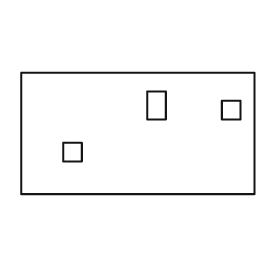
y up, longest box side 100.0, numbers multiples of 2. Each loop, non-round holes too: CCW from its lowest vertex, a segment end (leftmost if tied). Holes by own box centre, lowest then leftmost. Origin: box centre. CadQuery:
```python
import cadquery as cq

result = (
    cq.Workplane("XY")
    .moveTo(-50.0, -26.0)
    .lineTo(50.0, -26.0)
    .lineTo(50.0, 26.0)
    .lineTo(-50.0, 26.0)
    .close()
    .moveTo(-32.0, -12.0)
    .lineTo(-24.0, -12.0)
    .lineTo(-24.0, -4.0)
    .lineTo(-32.0, -4.0)
    .close()
    .moveTo(36.0, 6.0)
    .lineTo(44.0, 6.0)
    .lineTo(44.0, 14.0)
    .lineTo(36.0, 14.0)
    .close()
    .moveTo(4.0, 6.0)
    .lineTo(12.0, 6.0)
    .lineTo(12.0, 18.0)
    .lineTo(4.0, 18.0)
    .close()
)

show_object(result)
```